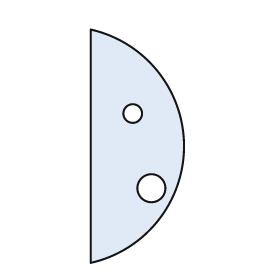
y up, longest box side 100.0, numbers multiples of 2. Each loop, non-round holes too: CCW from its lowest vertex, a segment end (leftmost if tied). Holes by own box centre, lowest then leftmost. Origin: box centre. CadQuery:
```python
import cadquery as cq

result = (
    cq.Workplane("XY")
    .moveTo(-20.0, -50.0)
    .threePointArc((20.0, 0.0), (-20.0, 50.0))
    .close()
    .moveTo(6.0, -18.0)
    .circle(6.0)
    .moveTo(-2.0, 14.0)
    .circle(4.0)
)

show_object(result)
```